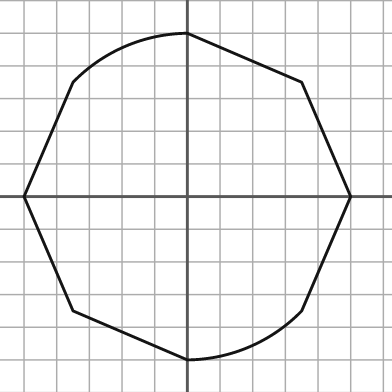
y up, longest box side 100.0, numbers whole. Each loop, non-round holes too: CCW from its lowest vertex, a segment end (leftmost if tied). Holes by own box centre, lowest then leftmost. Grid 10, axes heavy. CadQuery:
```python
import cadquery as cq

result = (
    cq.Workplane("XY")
    .moveTo(0.0, -50.0)
    .threePointArc((19.0, -46.0), (35.0, -35.0))
    .lineTo(50.0, 0.0)
    .lineTo(35.0, 35.0)
    .lineTo(0.0, 50.0)
    .threePointArc((-19.0, 46.0), (-35.0, 35.0))
    .lineTo(-50.0, 0.0)
    .lineTo(-35.0, -35.0)
    .close()
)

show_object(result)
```